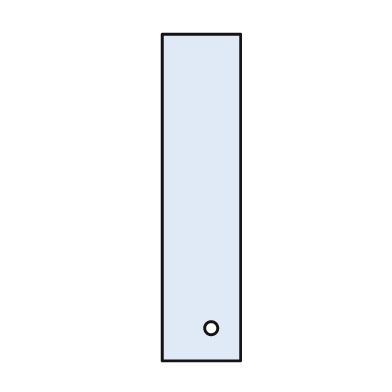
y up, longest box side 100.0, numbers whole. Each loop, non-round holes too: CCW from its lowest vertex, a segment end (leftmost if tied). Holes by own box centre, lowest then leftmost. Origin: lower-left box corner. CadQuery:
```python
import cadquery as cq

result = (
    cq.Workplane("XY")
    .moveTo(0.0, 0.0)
    .lineTo(24.0, 0.0)
    .lineTo(24.0, 100.0)
    .lineTo(0.0, 100.0)
    .close()
    .moveTo(15.0, 10.0)
    .circle(2.0)
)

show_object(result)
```